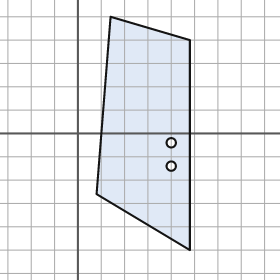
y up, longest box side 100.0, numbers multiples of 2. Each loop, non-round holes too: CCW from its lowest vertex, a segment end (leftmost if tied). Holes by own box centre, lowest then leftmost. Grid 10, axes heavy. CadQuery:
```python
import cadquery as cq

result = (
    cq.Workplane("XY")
    .moveTo(48.0, -50.0)
    .lineTo(48.0, 40.0)
    .lineTo(14.0, 50.0)
    .lineTo(8.0, -26.0)
    .close()
    .moveTo(40.0, -14.0)
    .circle(2.0)
    .moveTo(40.0, -4.0)
    .circle(2.0)
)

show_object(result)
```